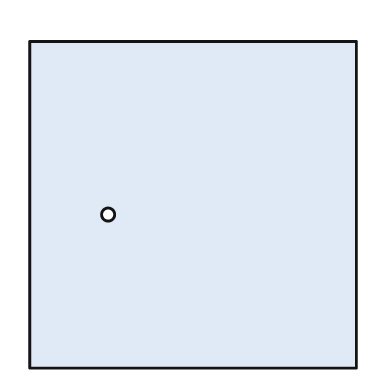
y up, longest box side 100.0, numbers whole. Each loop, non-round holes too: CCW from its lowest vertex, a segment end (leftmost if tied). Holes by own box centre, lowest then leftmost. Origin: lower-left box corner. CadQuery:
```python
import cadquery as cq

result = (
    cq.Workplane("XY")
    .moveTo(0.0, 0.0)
    .lineTo(100.0, 0.0)
    .lineTo(100.0, 100.0)
    .lineTo(0.0, 100.0)
    .close()
    .moveTo(24.0, 47.0)
    .circle(2.0)
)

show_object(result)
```